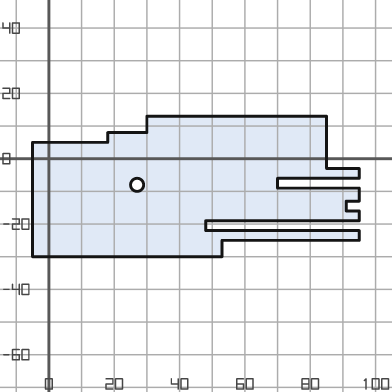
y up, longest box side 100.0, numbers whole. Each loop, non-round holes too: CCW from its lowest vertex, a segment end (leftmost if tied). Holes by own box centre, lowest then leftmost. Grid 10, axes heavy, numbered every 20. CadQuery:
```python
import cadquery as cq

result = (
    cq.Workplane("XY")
    .moveTo(-5.0, -30.0)
    .lineTo(53.0, -30.0)
    .lineTo(53.0, -25.0)
    .lineTo(95.0, -25.0)
    .lineTo(95.0, -22.0)
    .lineTo(48.0, -22.0)
    .lineTo(48.0, -19.0)
    .lineTo(95.0, -19.0)
    .lineTo(95.0, -16.0)
    .lineTo(91.0, -16.0)
    .lineTo(91.0, -13.0)
    .lineTo(95.0, -13.0)
    .lineTo(95.0, -9.0)
    .lineTo(70.0, -9.0)
    .lineTo(70.0, -6.0)
    .lineTo(95.0, -6.0)
    .lineTo(95.0, -3.0)
    .lineTo(85.0, -3.0)
    .lineTo(85.0, 13.0)
    .lineTo(30.0, 13.0)
    .lineTo(30.0, 8.0)
    .lineTo(18.0, 8.0)
    .lineTo(18.0, 5.0)
    .lineTo(-5.0, 5.0)
    .close()
    .moveTo(27.0, -8.0)
    .circle(2.0)
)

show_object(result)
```